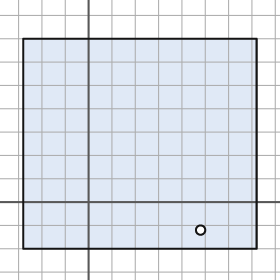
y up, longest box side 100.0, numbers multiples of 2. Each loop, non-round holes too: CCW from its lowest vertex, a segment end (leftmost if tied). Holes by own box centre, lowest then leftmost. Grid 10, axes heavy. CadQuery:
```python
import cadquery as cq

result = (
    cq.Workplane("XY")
    .moveTo(-28.0, -20.0)
    .lineTo(72.0, -20.0)
    .lineTo(72.0, 70.0)
    .lineTo(-28.0, 70.0)
    .close()
    .moveTo(48.0, -12.0)
    .circle(2.0)
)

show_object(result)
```